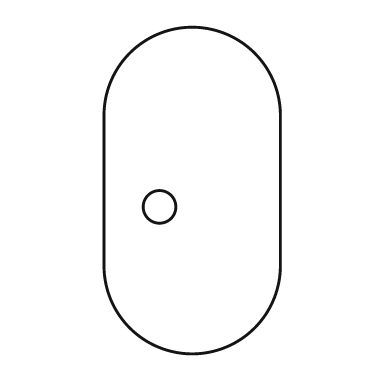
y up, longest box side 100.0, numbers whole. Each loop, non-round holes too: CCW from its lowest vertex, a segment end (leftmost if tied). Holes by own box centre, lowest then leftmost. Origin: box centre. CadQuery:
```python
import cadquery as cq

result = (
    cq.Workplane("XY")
    .moveTo(-27.0, -23.0)
    .threePointArc((0.0, -50.0), (27.0, -23.0))
    .lineTo(27.0, 23.0)
    .threePointArc((0.0, 50.0), (-27.0, 23.0))
    .close()
    .moveTo(-10.0, -5.0)
    .circle(5.0)
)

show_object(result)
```